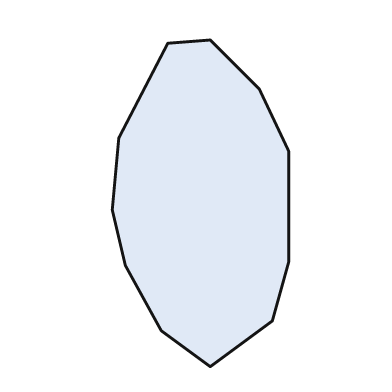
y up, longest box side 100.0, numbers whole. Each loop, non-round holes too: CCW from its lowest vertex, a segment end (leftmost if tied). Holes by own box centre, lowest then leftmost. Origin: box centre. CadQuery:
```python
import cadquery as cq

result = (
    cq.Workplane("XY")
    .moveTo(3.0, -50.0)
    .lineTo(22.0, -36.0)
    .lineTo(27.0, -18.0)
    .lineTo(27.0, 16.0)
    .lineTo(18.0, 35.0)
    .lineTo(3.0, 50.0)
    .lineTo(-10.0, 49.0)
    .lineTo(-25.0, 20.0)
    .lineTo(-27.0, -2.0)
    .lineTo(-23.0, -19.0)
    .lineTo(-12.0, -39.0)
    .close()
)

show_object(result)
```